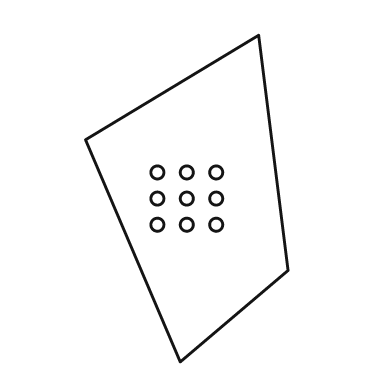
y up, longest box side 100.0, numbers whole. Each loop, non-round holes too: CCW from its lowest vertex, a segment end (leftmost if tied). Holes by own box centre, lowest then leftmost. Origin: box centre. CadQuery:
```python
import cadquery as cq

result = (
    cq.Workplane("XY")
    .moveTo(-2.0, -50.0)
    .lineTo(31.0, -22.0)
    .lineTo(22.0, 50.0)
    .lineTo(-31.0, 18.0)
    .close()
    .moveTo(-9.0, -8.0)
    .circle(2.0)
    .moveTo(0.0, -8.0)
    .circle(2.0)
    .moveTo(9.0, -8.0)
    .circle(2.0)
    .moveTo(-9.0, 0.0)
    .circle(2.0)
    .moveTo(0.0, 0.0)
    .circle(2.0)
    .moveTo(9.0, 0.0)
    .circle(2.0)
    .moveTo(-9.0, 8.0)
    .circle(2.0)
    .moveTo(0.0, 8.0)
    .circle(2.0)
    .moveTo(9.0, 8.0)
    .circle(2.0)
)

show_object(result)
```